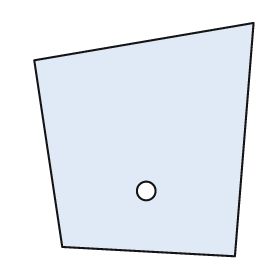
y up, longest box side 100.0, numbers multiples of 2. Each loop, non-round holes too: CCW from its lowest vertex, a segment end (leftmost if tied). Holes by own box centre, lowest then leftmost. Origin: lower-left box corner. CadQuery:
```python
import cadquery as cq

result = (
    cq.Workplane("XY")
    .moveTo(86.0, 0.0)
    .lineTo(94.0, 100.0)
    .lineTo(0.0, 84.0)
    .lineTo(12.0, 4.0)
    .close()
    .moveTo(48.0, 28.0)
    .circle(4.0)
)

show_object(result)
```